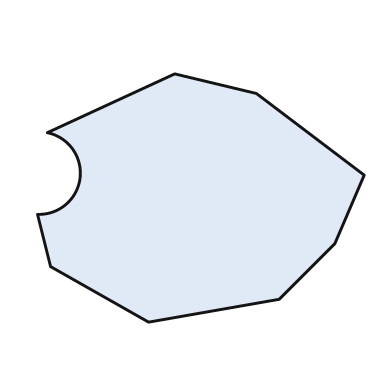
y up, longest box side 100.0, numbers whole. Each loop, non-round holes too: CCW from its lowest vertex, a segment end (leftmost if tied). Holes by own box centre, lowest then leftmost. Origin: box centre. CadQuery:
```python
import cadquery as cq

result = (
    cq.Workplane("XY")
    .moveTo(-16.0, -38.0)
    .lineTo(24.0, -31.0)
    .lineTo(41.0, -14.0)
    .lineTo(50.0, 7.0)
    .lineTo(17.0, 32.0)
    .lineTo(-8.0, 38.0)
    .lineTo(-47.0, 20.0)
    .threePointArc((-37.0, 6.0), (-50.0, -5.0))
    .lineTo(-46.0, -21.0)
    .close()
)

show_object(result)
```